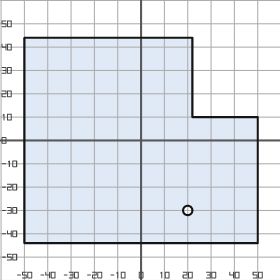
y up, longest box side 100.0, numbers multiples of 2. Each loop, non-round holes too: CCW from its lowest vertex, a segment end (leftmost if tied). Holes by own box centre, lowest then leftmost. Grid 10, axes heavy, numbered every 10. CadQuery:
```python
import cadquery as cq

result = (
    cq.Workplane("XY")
    .moveTo(-50.0, -44.0)
    .lineTo(50.0, -44.0)
    .lineTo(50.0, 10.0)
    .lineTo(22.0, 10.0)
    .lineTo(22.0, 44.0)
    .lineTo(-50.0, 44.0)
    .close()
    .moveTo(20.0, -30.0)
    .circle(2.0)
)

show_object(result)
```